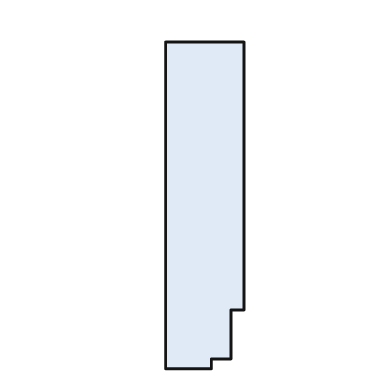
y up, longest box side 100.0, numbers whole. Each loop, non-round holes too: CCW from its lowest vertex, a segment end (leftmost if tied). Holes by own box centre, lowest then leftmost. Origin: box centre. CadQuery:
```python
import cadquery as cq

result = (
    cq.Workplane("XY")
    .moveTo(-12.0, -50.0)
    .lineTo(2.0, -50.0)
    .lineTo(2.0, -47.0)
    .lineTo(8.0, -47.0)
    .lineTo(8.0, -32.0)
    .lineTo(12.0, -32.0)
    .lineTo(12.0, 50.0)
    .lineTo(-12.0, 50.0)
    .close()
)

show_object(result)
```